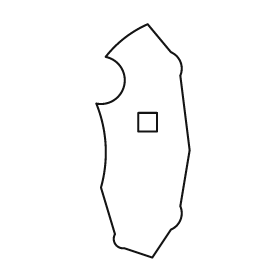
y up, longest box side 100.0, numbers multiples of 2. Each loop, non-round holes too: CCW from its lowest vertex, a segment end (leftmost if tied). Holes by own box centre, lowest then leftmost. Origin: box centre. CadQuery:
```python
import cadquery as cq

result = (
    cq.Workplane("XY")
    .moveTo(4.0, -50.0)
    .lineTo(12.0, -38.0)
    .threePointArc((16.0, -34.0), (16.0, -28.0))
    .lineTo(20.0, -4.0)
    .lineTo(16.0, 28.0)
    .threePointArc((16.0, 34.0), (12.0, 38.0))
    .lineTo(2.0, 50.0)
    .threePointArc((-8.0, 44.0), (-16.0, 36.0))
    .threePointArc((-8.0, 24.0), (-20.0, 16.0))
    .threePointArc((-16.0, -2.0), (-18.0, -20.0))
    .lineTo(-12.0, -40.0)
    .threePointArc((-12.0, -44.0), (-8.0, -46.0))
    .close()
    .moveTo(-2.0, 4.0)
    .lineTo(6.0, 4.0)
    .lineTo(6.0, 12.0)
    .lineTo(-2.0, 12.0)
    .close()
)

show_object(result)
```